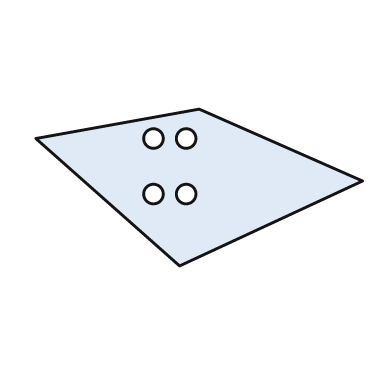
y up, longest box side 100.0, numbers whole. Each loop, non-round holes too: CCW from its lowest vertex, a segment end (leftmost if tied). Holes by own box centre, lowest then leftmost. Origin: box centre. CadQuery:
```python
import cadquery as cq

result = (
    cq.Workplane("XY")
    .moveTo(-6.0, -24.0)
    .lineTo(50.0, 2.0)
    .lineTo(0.0, 24.0)
    .lineTo(-50.0, 15.0)
    .close()
    .moveTo(-14.0, -2.0)
    .circle(3.0)
    .moveTo(-4.0, -2.0)
    .circle(3.0)
    .moveTo(-14.0, 15.0)
    .circle(3.0)
    .moveTo(-4.0, 15.0)
    .circle(3.0)
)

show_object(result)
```